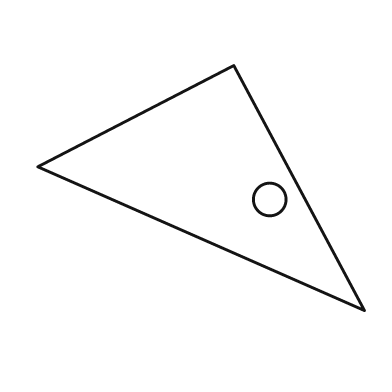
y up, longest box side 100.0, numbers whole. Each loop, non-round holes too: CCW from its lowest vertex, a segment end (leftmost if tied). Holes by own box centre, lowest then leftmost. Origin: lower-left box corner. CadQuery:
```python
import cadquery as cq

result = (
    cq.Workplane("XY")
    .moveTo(100.0, 0.0)
    .lineTo(60.0, 75.0)
    .lineTo(0.0, 44.0)
    .close()
    .moveTo(71.0, 34.0)
    .circle(5.0)
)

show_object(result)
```